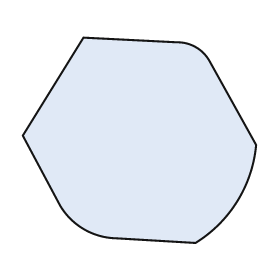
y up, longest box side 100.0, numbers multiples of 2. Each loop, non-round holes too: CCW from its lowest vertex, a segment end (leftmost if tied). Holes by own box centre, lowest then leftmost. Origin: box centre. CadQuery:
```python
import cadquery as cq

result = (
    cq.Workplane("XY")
    .moveTo(24.0, -44.0)
    .threePointArc((42.0, -26.0), (50.0, -2.0))
    .lineTo(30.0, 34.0)
    .threePointArc((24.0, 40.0), (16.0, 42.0))
    .lineTo(-24.0, 44.0)
    .lineTo(-50.0, 2.0)
    .lineTo(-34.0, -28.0)
    .threePointArc((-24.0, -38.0), (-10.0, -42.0))
    .close()
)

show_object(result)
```